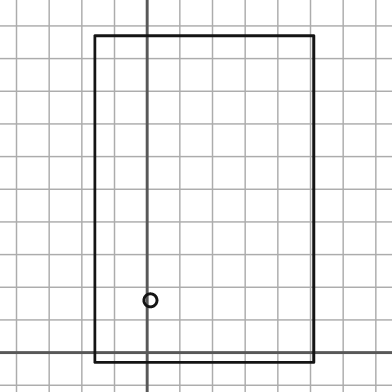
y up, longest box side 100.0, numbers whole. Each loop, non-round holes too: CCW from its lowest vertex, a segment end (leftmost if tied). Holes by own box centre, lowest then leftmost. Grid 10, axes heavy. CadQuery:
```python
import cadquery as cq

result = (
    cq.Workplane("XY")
    .moveTo(-16.0, -3.0)
    .lineTo(51.0, -3.0)
    .lineTo(51.0, 97.0)
    .lineTo(-16.0, 97.0)
    .close()
    .moveTo(1.0, 16.0)
    .circle(2.0)
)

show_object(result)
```